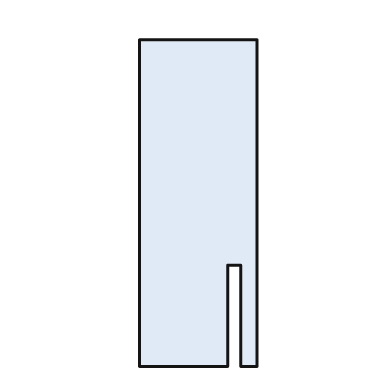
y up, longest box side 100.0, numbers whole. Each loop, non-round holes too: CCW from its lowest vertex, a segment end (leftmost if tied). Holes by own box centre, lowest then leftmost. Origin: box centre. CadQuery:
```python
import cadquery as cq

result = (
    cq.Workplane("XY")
    .moveTo(-18.0, -50.0)
    .lineTo(9.0, -50.0)
    .lineTo(9.0, -19.0)
    .lineTo(13.0, -19.0)
    .lineTo(13.0, -50.0)
    .lineTo(18.0, -50.0)
    .lineTo(18.0, 50.0)
    .lineTo(-18.0, 50.0)
    .close()
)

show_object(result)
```